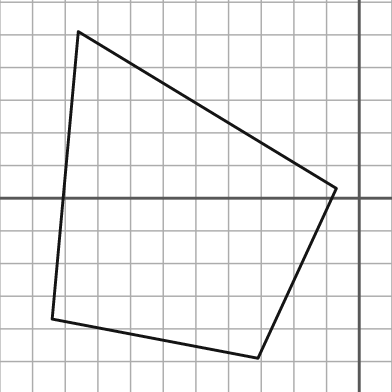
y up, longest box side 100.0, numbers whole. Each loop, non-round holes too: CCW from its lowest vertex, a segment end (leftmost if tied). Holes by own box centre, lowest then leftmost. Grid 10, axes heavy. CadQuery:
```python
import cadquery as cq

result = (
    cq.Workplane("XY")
    .moveTo(-31.0, -49.0)
    .lineTo(-7.0, 3.0)
    .lineTo(-86.0, 51.0)
    .lineTo(-94.0, -37.0)
    .close()
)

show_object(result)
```